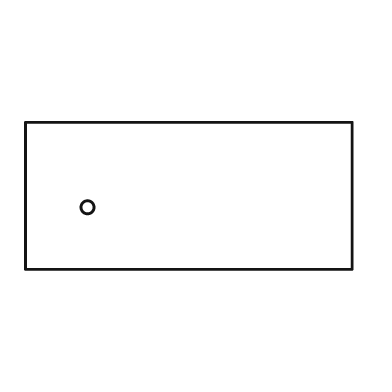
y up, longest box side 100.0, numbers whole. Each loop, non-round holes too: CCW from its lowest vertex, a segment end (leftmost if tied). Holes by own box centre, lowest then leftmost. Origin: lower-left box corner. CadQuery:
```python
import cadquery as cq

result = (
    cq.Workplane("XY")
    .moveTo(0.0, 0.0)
    .lineTo(100.0, 0.0)
    .lineTo(100.0, 45.0)
    .lineTo(0.0, 45.0)
    .close()
    .moveTo(19.0, 19.0)
    .circle(2.0)
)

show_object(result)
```